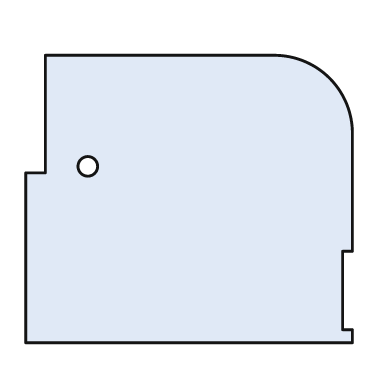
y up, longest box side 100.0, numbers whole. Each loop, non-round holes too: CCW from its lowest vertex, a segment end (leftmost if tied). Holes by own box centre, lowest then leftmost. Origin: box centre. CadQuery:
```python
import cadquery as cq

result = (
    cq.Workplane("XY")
    .moveTo(-50.0, -44.0)
    .lineTo(50.0, -44.0)
    .lineTo(50.0, -40.0)
    .lineTo(47.0, -40.0)
    .lineTo(47.0, -16.0)
    .lineTo(50.0, -16.0)
    .lineTo(50.0, 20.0)
    .threePointArc((43.0, 37.0), (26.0, 44.0))
    .lineTo(-44.0, 44.0)
    .lineTo(-44.0, 8.0)
    .lineTo(-50.0, 8.0)
    .close()
    .moveTo(-31.0, 10.0)
    .circle(3.0)
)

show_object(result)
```